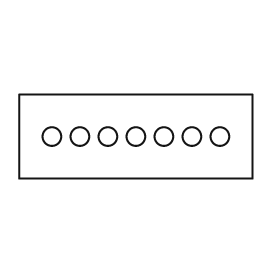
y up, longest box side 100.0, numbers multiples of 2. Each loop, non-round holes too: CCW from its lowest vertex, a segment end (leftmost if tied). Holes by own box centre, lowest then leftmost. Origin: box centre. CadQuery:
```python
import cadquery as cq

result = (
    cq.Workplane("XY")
    .moveTo(-50.0, -18.0)
    .lineTo(50.0, -18.0)
    .lineTo(50.0, 18.0)
    .lineTo(-50.0, 18.0)
    .close()
    .moveTo(-36.0, 0.0)
    .circle(4.0)
    .moveTo(-24.0, 0.0)
    .circle(4.0)
    .moveTo(-12.0, 0.0)
    .circle(4.0)
    .moveTo(0.0, 0.0)
    .circle(4.0)
    .moveTo(12.0, 0.0)
    .circle(4.0)
    .moveTo(24.0, 0.0)
    .circle(4.0)
    .moveTo(36.0, 0.0)
    .circle(4.0)
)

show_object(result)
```